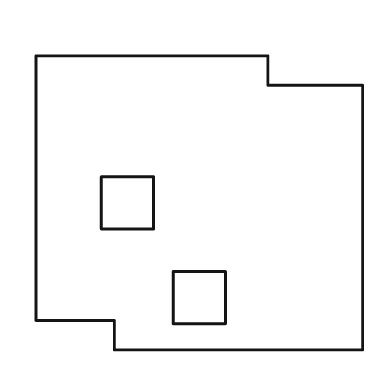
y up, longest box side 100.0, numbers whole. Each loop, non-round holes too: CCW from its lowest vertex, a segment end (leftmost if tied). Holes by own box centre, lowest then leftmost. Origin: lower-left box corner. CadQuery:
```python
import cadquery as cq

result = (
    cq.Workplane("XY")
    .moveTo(24.0, 0.0)
    .lineTo(100.0, 0.0)
    .lineTo(100.0, 81.0)
    .lineTo(71.0, 81.0)
    .lineTo(71.0, 90.0)
    .lineTo(0.0, 90.0)
    .lineTo(0.0, 9.0)
    .lineTo(24.0, 9.0)
    .close()
    .moveTo(42.0, 8.0)
    .lineTo(58.0, 8.0)
    .lineTo(58.0, 24.0)
    .lineTo(42.0, 24.0)
    .close()
    .moveTo(20.0, 37.0)
    .lineTo(36.0, 37.0)
    .lineTo(36.0, 53.0)
    .lineTo(20.0, 53.0)
    .close()
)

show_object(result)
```